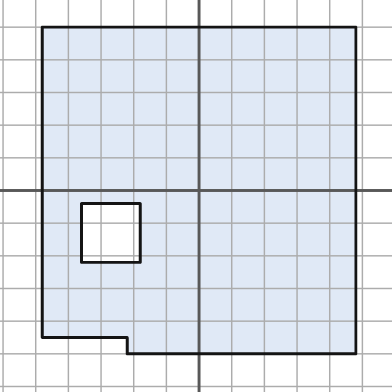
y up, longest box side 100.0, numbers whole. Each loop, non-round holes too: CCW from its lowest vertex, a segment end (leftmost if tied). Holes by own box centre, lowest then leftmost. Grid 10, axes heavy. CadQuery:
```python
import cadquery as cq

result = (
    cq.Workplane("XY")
    .moveTo(-22.0, -50.0)
    .lineTo(48.0, -50.0)
    .lineTo(48.0, 50.0)
    .lineTo(-48.0, 50.0)
    .lineTo(-48.0, -45.0)
    .lineTo(-22.0, -45.0)
    .close()
    .moveTo(-36.0, -22.0)
    .lineTo(-18.0, -22.0)
    .lineTo(-18.0, -4.0)
    .lineTo(-36.0, -4.0)
    .close()
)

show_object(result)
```